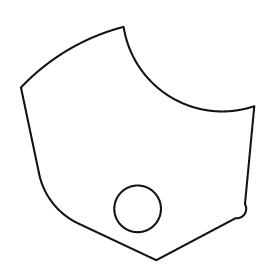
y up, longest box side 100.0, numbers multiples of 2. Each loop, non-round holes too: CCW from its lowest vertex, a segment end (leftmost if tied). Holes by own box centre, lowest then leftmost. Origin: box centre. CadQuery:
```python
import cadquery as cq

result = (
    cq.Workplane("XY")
    .moveTo(8.0, -50.0)
    .lineTo(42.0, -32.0)
    .threePointArc((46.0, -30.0), (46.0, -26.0))
    .lineTo(50.0, 16.0)
    .threePointArc((14.0, 20.0), (-6.0, 50.0))
    .threePointArc((-30.0, 40.0), (-50.0, 24.0))
    .lineTo(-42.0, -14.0)
    .threePointArc((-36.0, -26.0), (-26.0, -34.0))
    .close()
    .moveTo(0.0, -28.0)
    .circle(10.0)
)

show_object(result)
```